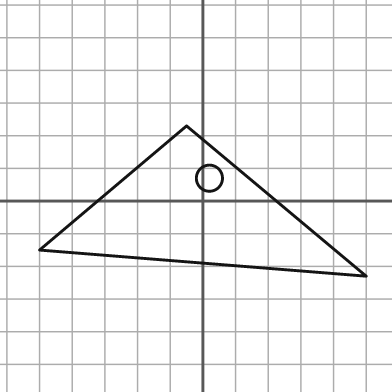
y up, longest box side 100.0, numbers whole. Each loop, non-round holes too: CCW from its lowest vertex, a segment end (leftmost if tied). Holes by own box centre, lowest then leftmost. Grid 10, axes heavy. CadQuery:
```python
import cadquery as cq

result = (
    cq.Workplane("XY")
    .moveTo(50.0, -23.0)
    .lineTo(-5.0, 23.0)
    .lineTo(-50.0, -15.0)
    .close()
    .moveTo(2.0, 7.0)
    .circle(4.0)
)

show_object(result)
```